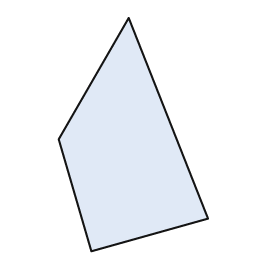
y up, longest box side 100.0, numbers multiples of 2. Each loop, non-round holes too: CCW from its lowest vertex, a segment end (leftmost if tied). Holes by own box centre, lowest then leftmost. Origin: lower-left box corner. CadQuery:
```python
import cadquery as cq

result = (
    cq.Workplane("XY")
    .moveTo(14.0, 0.0)
    .lineTo(64.0, 14.0)
    .lineTo(30.0, 100.0)
    .lineTo(0.0, 48.0)
    .close()
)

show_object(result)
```